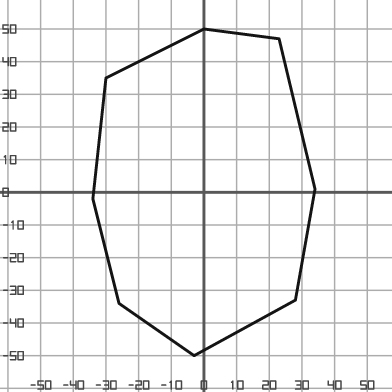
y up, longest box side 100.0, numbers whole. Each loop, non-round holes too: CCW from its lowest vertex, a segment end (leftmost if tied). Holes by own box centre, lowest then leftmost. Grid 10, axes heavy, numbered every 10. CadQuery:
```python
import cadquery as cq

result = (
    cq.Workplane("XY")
    .moveTo(-3.0, -50.0)
    .lineTo(28.0, -33.0)
    .lineTo(34.0, 1.0)
    .lineTo(23.0, 47.0)
    .lineTo(0.0, 50.0)
    .lineTo(-30.0, 35.0)
    .lineTo(-34.0, -2.0)
    .lineTo(-26.0, -34.0)
    .close()
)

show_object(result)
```